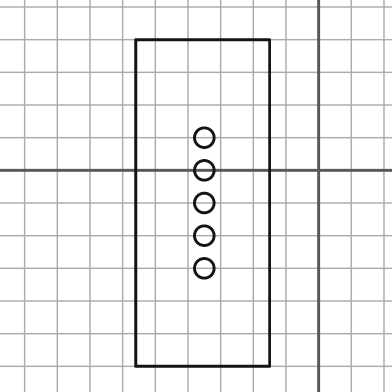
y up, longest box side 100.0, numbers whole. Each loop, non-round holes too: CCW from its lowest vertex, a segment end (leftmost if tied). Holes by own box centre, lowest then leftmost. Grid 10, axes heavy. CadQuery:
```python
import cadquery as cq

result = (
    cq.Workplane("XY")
    .moveTo(-56.0, -60.0)
    .lineTo(-15.0, -60.0)
    .lineTo(-15.0, 40.0)
    .lineTo(-56.0, 40.0)
    .close()
    .moveTo(-35.0, -30.0)
    .circle(3.0)
    .moveTo(-35.0, -20.0)
    .circle(3.0)
    .moveTo(-35.0, -10.0)
    .circle(3.0)
    .moveTo(-35.0, 0.0)
    .circle(3.0)
    .moveTo(-35.0, 10.0)
    .circle(3.0)
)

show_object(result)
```